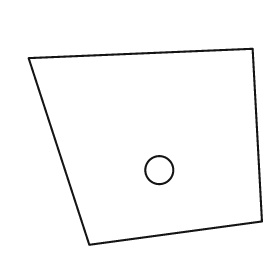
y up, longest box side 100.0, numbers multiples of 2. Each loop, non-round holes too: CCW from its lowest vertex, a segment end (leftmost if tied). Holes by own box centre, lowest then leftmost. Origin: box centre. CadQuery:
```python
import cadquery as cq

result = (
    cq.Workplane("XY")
    .moveTo(-24.0, -42.0)
    .lineTo(50.0, -32.0)
    .lineTo(46.0, 42.0)
    .lineTo(-50.0, 38.0)
    .close()
    .moveTo(6.0, -10.0)
    .circle(6.0)
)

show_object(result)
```